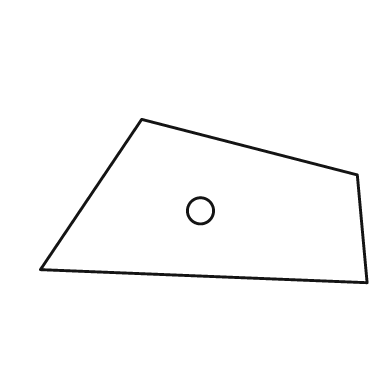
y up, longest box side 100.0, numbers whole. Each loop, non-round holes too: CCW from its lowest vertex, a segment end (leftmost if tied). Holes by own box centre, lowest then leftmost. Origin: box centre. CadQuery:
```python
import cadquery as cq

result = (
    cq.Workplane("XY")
    .moveTo(50.0, -25.0)
    .lineTo(47.0, 8.0)
    .lineTo(-19.0, 25.0)
    .lineTo(-50.0, -21.0)
    .close()
    .moveTo(-1.0, -3.0)
    .circle(4.0)
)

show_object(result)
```